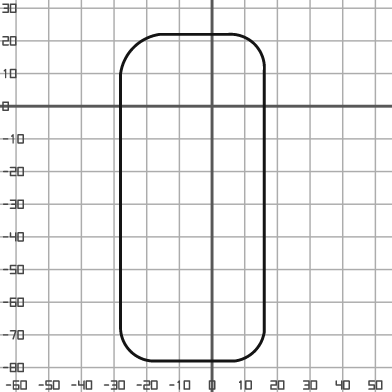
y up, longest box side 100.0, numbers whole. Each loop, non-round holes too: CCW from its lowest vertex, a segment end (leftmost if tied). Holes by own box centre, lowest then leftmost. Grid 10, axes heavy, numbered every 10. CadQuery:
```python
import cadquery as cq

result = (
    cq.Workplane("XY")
    .moveTo(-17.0, -78.0)
    .lineTo(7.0, -78.0)
    .threePointArc((13.0, -75.0), (16.0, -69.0))
    .lineTo(16.0, 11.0)
    .threePointArc((13.0, 19.0), (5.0, 22.0))
    .lineTo(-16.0, 22.0)
    .threePointArc((-24.0, 18.0), (-28.0, 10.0))
    .lineTo(-28.0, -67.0)
    .threePointArc((-25.0, -75.0), (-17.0, -78.0))
    .close()
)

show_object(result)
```